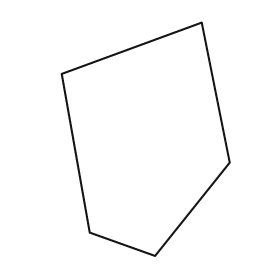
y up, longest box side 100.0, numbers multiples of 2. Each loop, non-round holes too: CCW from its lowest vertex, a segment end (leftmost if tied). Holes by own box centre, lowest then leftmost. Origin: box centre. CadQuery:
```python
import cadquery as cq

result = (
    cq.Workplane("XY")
    .moveTo(4.0, -50.0)
    .lineTo(36.0, -10.0)
    .lineTo(24.0, 50.0)
    .lineTo(-36.0, 28.0)
    .lineTo(-24.0, -40.0)
    .close()
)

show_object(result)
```